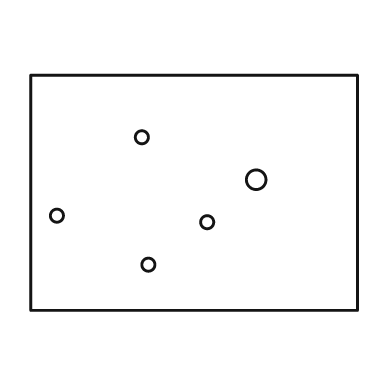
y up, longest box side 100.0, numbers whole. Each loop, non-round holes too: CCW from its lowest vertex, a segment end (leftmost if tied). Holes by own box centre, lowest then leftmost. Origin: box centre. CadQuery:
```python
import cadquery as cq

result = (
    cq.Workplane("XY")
    .moveTo(-50.0, -36.0)
    .lineTo(50.0, -36.0)
    .lineTo(50.0, 36.0)
    .lineTo(-50.0, 36.0)
    .close()
    .moveTo(-14.0, -22.0)
    .circle(2.0)
    .moveTo(4.0, -9.0)
    .circle(2.0)
    .moveTo(-42.0, -7.0)
    .circle(2.0)
    .moveTo(19.0, 4.0)
    .circle(3.0)
    .moveTo(-16.0, 17.0)
    .circle(2.0)
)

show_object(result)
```